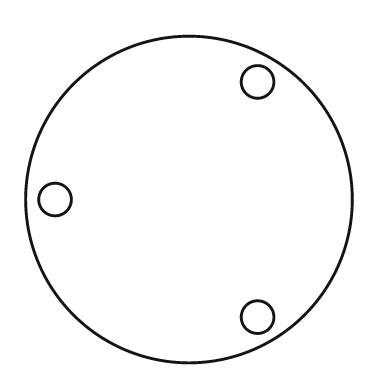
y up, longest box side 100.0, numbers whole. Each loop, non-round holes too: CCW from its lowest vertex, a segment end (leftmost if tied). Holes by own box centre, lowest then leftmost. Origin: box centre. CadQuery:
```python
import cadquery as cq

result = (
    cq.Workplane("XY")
    .moveTo(0.0, 0.0)
    .circle(50.0)
    .moveTo(21.0, -36.0)
    .circle(5.0)
    .moveTo(-41.0, 0.0)
    .circle(5.0)
    .moveTo(21.0, 36.0)
    .circle(5.0)
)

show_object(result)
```